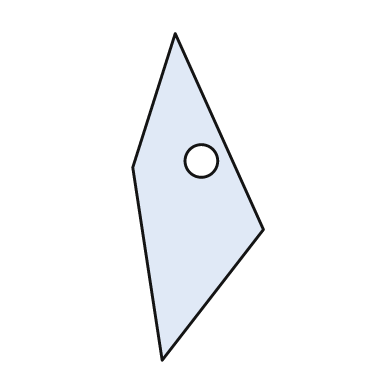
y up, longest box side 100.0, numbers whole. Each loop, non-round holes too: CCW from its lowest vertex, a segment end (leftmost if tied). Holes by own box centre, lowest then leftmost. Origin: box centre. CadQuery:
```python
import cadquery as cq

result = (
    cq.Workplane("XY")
    .moveTo(-11.0, -50.0)
    .lineTo(20.0, -10.0)
    .lineTo(-7.0, 50.0)
    .lineTo(-20.0, 9.0)
    .close()
    .moveTo(1.0, 11.0)
    .circle(5.0)
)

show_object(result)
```